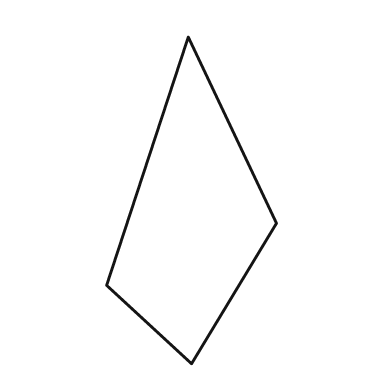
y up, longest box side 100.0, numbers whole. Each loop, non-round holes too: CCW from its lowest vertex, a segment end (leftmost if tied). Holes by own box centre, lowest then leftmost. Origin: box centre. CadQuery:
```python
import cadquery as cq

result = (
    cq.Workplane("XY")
    .moveTo(0.0, -50.0)
    .lineTo(26.0, -7.0)
    .lineTo(-1.0, 50.0)
    .lineTo(-26.0, -26.0)
    .close()
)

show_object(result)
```